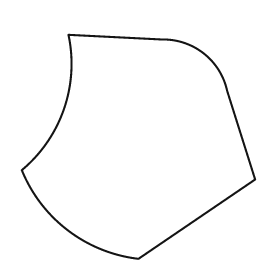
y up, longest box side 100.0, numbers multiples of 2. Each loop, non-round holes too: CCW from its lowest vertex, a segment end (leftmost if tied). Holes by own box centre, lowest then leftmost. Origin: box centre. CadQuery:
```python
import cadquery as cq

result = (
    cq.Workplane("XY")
    .moveTo(0.0, -48.0)
    .lineTo(50.0, -14.0)
    .lineTo(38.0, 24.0)
    .threePointArc((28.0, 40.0), (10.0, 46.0))
    .lineTo(-30.0, 48.0)
    .threePointArc((-32.0, 16.0), (-50.0, -10.0))
    .threePointArc((-30.0, -36.0), (0.0, -48.0))
    .close()
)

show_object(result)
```